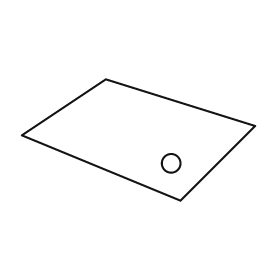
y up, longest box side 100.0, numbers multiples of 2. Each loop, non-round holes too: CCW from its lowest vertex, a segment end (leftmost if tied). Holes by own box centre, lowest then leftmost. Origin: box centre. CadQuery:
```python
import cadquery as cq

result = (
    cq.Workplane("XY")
    .moveTo(18.0, -26.0)
    .lineTo(50.0, 6.0)
    .lineTo(-14.0, 26.0)
    .lineTo(-50.0, 2.0)
    .close()
    .moveTo(14.0, -10.0)
    .circle(4.0)
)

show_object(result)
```